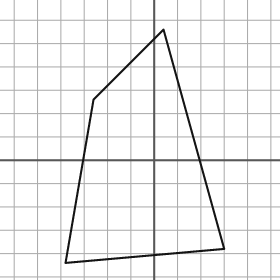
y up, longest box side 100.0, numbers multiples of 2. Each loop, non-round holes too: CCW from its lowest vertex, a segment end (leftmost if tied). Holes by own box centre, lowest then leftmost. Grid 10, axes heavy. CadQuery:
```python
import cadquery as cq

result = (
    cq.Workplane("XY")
    .moveTo(-38.0, -44.0)
    .lineTo(30.0, -38.0)
    .lineTo(4.0, 56.0)
    .lineTo(-26.0, 26.0)
    .close()
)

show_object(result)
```